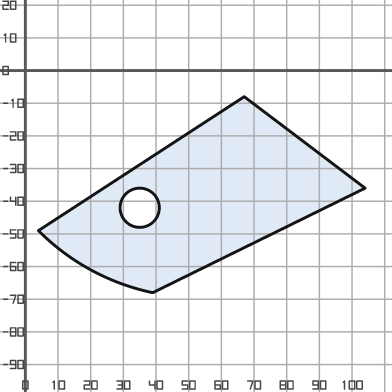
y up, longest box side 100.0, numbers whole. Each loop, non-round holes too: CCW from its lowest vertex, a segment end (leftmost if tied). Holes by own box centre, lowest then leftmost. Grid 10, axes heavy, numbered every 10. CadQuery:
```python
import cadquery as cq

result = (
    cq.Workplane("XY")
    .moveTo(39.0, -68.0)
    .lineTo(104.0, -36.0)
    .lineTo(67.0, -8.0)
    .lineTo(4.0, -49.0)
    .threePointArc((20.0, -61.0), (39.0, -68.0))
    .close()
    .moveTo(35.0, -42.0)
    .circle(6.0)
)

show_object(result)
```